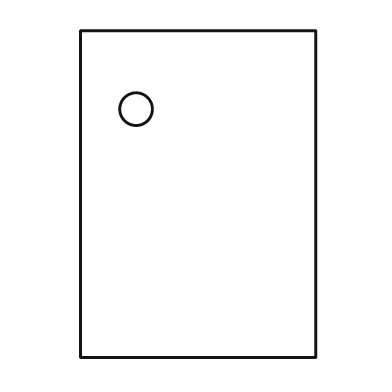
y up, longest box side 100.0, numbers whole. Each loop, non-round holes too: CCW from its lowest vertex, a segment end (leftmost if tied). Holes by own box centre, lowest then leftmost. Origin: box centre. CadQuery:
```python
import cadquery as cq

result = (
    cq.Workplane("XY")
    .moveTo(-36.0, -50.0)
    .lineTo(36.0, -50.0)
    .lineTo(36.0, 50.0)
    .lineTo(-36.0, 50.0)
    .close()
    .moveTo(-19.0, 26.0)
    .circle(5.0)
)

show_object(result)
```